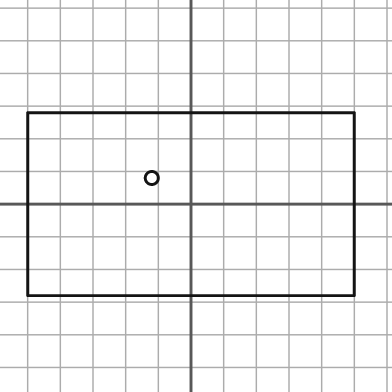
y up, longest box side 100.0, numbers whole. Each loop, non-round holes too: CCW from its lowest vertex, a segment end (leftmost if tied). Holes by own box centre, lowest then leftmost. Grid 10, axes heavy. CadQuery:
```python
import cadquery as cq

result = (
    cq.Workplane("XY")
    .moveTo(-50.0, -28.0)
    .lineTo(50.0, -28.0)
    .lineTo(50.0, 28.0)
    .lineTo(-50.0, 28.0)
    .close()
    .moveTo(-12.0, 8.0)
    .circle(2.0)
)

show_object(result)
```